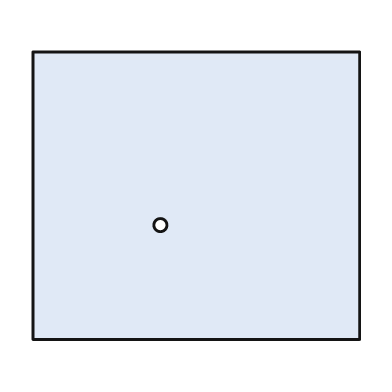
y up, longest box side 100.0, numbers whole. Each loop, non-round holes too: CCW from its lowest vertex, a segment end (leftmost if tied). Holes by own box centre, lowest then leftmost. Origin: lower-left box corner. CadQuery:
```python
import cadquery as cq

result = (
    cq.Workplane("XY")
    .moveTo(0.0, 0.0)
    .lineTo(100.0, 0.0)
    .lineTo(100.0, 88.0)
    .lineTo(0.0, 88.0)
    .close()
    .moveTo(39.0, 35.0)
    .circle(2.0)
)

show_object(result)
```